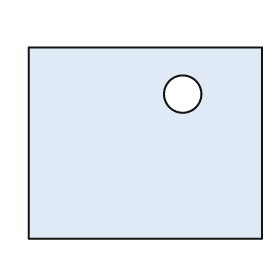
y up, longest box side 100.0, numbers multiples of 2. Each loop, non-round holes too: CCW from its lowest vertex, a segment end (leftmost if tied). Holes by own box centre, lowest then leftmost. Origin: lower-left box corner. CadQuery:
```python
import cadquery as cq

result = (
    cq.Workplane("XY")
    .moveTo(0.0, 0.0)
    .lineTo(100.0, 0.0)
    .lineTo(100.0, 82.0)
    .lineTo(0.0, 82.0)
    .close()
    .moveTo(66.0, 62.0)
    .circle(8.0)
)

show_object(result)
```